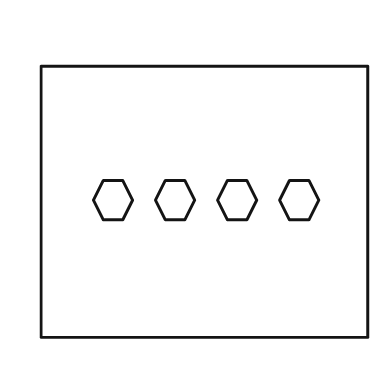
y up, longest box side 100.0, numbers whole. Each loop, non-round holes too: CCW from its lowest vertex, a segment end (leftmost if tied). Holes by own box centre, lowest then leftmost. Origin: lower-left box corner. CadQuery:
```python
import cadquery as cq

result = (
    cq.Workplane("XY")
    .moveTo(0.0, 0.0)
    .lineTo(100.0, 0.0)
    .lineTo(100.0, 83.0)
    .lineTo(0.0, 83.0)
    .close()
    .moveTo(19.0, 36.0)
    .lineTo(25.0, 36.0)
    .lineTo(28.0, 42.0)
    .lineTo(25.0, 48.0)
    .lineTo(19.0, 48.0)
    .lineTo(16.0, 42.0)
    .close()
    .moveTo(38.0, 36.0)
    .lineTo(44.0, 36.0)
    .lineTo(47.0, 42.0)
    .lineTo(44.0, 48.0)
    .lineTo(38.0, 48.0)
    .lineTo(35.0, 42.0)
    .close()
    .moveTo(57.0, 36.0)
    .lineTo(63.0, 36.0)
    .lineTo(66.0, 42.0)
    .lineTo(63.0, 48.0)
    .lineTo(57.0, 48.0)
    .lineTo(54.0, 42.0)
    .close()
    .moveTo(76.0, 36.0)
    .lineTo(82.0, 36.0)
    .lineTo(85.0, 42.0)
    .lineTo(82.0, 48.0)
    .lineTo(76.0, 48.0)
    .lineTo(73.0, 42.0)
    .close()
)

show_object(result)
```